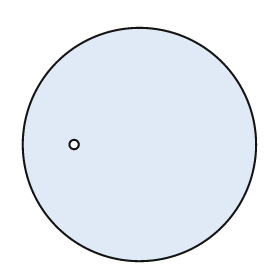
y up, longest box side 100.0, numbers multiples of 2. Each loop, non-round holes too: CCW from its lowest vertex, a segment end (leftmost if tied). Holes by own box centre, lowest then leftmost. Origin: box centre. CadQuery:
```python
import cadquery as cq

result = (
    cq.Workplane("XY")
    .moveTo(0.0, 0.0)
    .circle(50.0)
    .moveTo(-28.0, 0.0)
    .circle(2.0)
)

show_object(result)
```